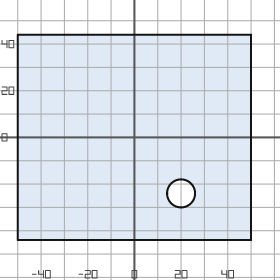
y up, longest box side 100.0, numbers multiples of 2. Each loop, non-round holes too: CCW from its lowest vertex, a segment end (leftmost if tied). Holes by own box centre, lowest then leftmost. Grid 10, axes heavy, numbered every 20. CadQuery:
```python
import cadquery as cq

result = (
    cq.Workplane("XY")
    .moveTo(-50.0, -44.0)
    .lineTo(50.0, -44.0)
    .lineTo(50.0, 44.0)
    .lineTo(-50.0, 44.0)
    .close()
    .moveTo(20.0, -24.0)
    .circle(6.0)
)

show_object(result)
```